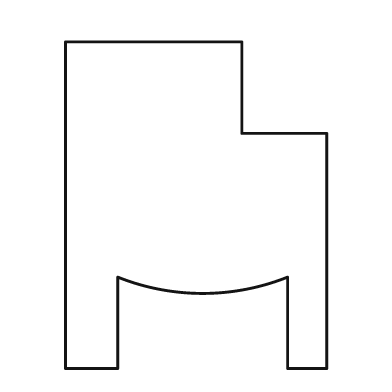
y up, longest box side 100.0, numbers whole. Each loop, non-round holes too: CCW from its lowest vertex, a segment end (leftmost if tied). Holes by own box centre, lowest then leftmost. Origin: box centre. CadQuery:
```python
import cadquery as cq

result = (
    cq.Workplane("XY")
    .moveTo(-40.0, -50.0)
    .lineTo(-24.0, -50.0)
    .lineTo(-24.0, -22.0)
    .threePointArc((2.0, -27.0), (28.0, -22.0))
    .lineTo(28.0, -50.0)
    .lineTo(40.0, -50.0)
    .lineTo(40.0, 22.0)
    .lineTo(14.0, 22.0)
    .lineTo(14.0, 50.0)
    .lineTo(-40.0, 50.0)
    .close()
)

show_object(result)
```